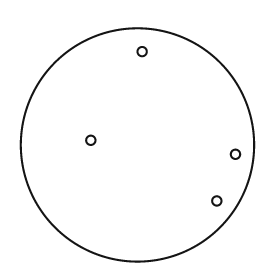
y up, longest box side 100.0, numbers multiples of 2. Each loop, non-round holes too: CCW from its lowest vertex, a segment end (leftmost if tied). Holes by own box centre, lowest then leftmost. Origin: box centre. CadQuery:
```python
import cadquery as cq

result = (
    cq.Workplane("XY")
    .moveTo(0.0, 0.0)
    .circle(50.0)
    .moveTo(34.0, -24.0)
    .circle(2.0)
    .moveTo(42.0, -4.0)
    .circle(2.0)
    .moveTo(-20.0, 2.0)
    .circle(2.0)
    .moveTo(2.0, 40.0)
    .circle(2.0)
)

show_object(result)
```